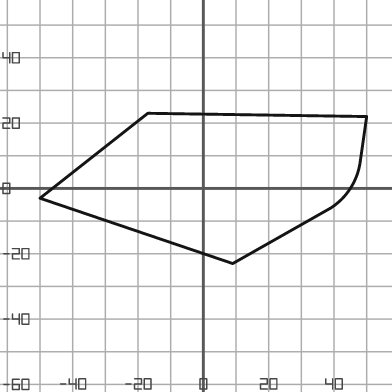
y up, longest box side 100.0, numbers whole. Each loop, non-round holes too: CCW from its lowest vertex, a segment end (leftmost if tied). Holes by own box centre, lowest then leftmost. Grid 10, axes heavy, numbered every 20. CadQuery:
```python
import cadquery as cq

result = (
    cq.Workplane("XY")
    .moveTo(9.0, -23.0)
    .lineTo(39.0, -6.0)
    .threePointArc((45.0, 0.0), (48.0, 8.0))
    .lineTo(50.0, 22.0)
    .lineTo(-17.0, 23.0)
    .lineTo(-50.0, -3.0)
    .close()
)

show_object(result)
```